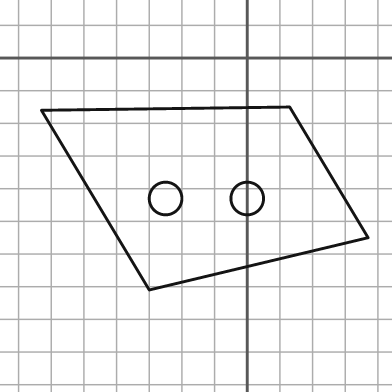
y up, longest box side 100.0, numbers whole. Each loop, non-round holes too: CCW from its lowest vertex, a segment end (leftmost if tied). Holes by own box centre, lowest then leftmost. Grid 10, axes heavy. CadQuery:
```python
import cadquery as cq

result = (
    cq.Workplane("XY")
    .moveTo(-30.0, -71.0)
    .lineTo(37.0, -55.0)
    .lineTo(13.0, -15.0)
    .lineTo(-63.0, -16.0)
    .close()
    .moveTo(-25.0, -43.0)
    .circle(5.0)
    .moveTo(0.0, -43.0)
    .circle(5.0)
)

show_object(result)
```